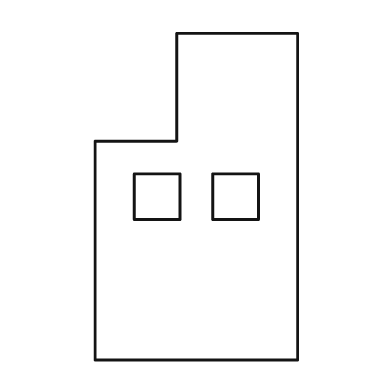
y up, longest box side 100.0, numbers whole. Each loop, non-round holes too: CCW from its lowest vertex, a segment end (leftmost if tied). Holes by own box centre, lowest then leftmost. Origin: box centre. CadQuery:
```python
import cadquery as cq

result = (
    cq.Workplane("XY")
    .moveTo(-31.0, -50.0)
    .lineTo(31.0, -50.0)
    .lineTo(31.0, 50.0)
    .lineTo(-6.0, 50.0)
    .lineTo(-6.0, 17.0)
    .lineTo(-31.0, 17.0)
    .close()
    .moveTo(-19.0, -7.0)
    .lineTo(-5.0, -7.0)
    .lineTo(-5.0, 7.0)
    .lineTo(-19.0, 7.0)
    .close()
    .moveTo(5.0, -7.0)
    .lineTo(19.0, -7.0)
    .lineTo(19.0, 7.0)
    .lineTo(5.0, 7.0)
    .close()
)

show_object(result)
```